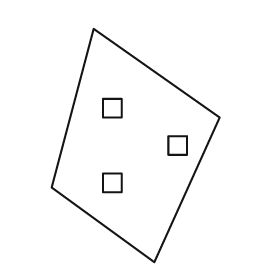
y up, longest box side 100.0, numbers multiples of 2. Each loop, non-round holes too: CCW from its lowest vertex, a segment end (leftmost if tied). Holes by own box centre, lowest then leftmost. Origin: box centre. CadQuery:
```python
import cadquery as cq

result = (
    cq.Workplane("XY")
    .moveTo(8.0, -50.0)
    .lineTo(36.0, 12.0)
    .lineTo(-18.0, 50.0)
    .lineTo(-36.0, -18.0)
    .close()
    .moveTo(-14.0, -20.0)
    .lineTo(-6.0, -20.0)
    .lineTo(-6.0, -12.0)
    .lineTo(-14.0, -12.0)
    .close()
    .moveTo(14.0, -4.0)
    .lineTo(22.0, -4.0)
    .lineTo(22.0, 4.0)
    .lineTo(14.0, 4.0)
    .close()
    .moveTo(-14.0, 12.0)
    .lineTo(-6.0, 12.0)
    .lineTo(-6.0, 20.0)
    .lineTo(-14.0, 20.0)
    .close()
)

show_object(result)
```